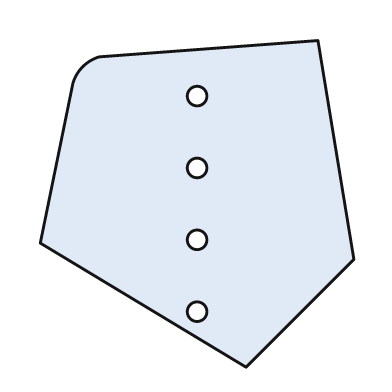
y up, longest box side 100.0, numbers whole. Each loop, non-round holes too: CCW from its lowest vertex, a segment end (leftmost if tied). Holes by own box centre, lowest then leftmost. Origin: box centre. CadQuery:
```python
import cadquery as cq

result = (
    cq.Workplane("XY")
    .moveTo(15.0, -50.0)
    .lineTo(48.0, -17.0)
    .lineTo(37.0, 50.0)
    .lineTo(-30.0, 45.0)
    .threePointArc((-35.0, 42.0), (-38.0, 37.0))
    .lineTo(-48.0, -12.0)
    .close()
    .moveTo(0.0, -33.0)
    .circle(3.0)
    .moveTo(0.0, -11.0)
    .circle(3.0)
    .moveTo(0.0, 11.0)
    .circle(3.0)
    .moveTo(0.0, 33.0)
    .circle(3.0)
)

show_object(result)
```